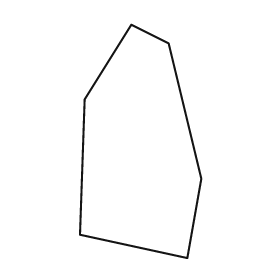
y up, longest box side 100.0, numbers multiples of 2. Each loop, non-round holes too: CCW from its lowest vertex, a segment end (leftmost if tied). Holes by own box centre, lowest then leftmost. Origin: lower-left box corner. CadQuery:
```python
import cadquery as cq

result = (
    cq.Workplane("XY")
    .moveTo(46.0, 0.0)
    .lineTo(52.0, 34.0)
    .lineTo(38.0, 92.0)
    .lineTo(22.0, 100.0)
    .lineTo(2.0, 68.0)
    .lineTo(0.0, 10.0)
    .close()
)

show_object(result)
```